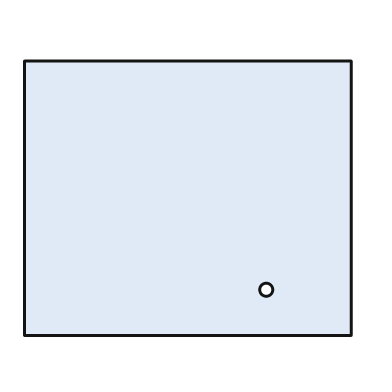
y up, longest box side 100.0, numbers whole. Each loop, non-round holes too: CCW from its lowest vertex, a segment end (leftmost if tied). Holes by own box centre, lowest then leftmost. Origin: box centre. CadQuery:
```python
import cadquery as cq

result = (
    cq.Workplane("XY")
    .moveTo(-50.0, -42.0)
    .lineTo(50.0, -42.0)
    .lineTo(50.0, 42.0)
    .lineTo(-50.0, 42.0)
    .close()
    .moveTo(24.0, -28.0)
    .circle(2.0)
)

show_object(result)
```